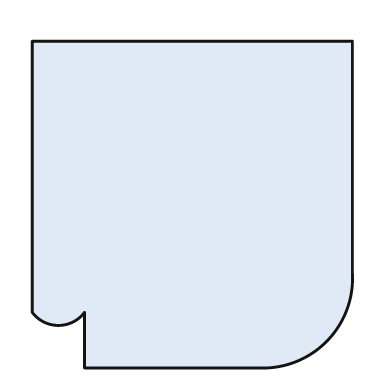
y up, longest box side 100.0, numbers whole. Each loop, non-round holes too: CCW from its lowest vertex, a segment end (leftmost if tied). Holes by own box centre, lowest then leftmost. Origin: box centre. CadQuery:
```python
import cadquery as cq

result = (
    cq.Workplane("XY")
    .moveTo(-33.0, -50.0)
    .lineTo(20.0, -50.0)
    .threePointArc((41.0, -42.0), (49.0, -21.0))
    .lineTo(49.0, 50.0)
    .lineTo(-49.0, 50.0)
    .lineTo(-49.0, -33.0)
    .threePointArc((-41.0, -37.0), (-33.0, -33.0))
    .close()
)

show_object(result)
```